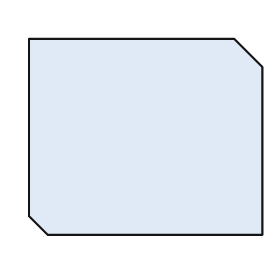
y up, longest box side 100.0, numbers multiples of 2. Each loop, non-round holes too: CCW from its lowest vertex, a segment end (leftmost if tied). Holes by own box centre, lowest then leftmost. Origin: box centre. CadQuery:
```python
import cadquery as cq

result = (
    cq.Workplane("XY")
    .moveTo(-42.0, -42.0)
    .lineTo(50.0, -42.0)
    .lineTo(50.0, 30.0)
    .lineTo(38.0, 42.0)
    .lineTo(-50.0, 42.0)
    .lineTo(-50.0, -34.0)
    .close()
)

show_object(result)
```